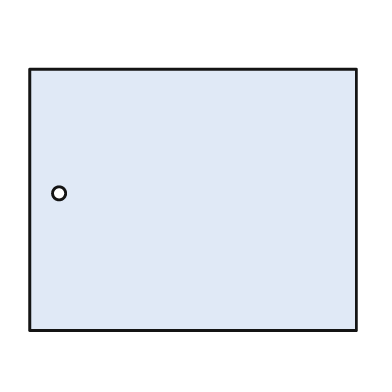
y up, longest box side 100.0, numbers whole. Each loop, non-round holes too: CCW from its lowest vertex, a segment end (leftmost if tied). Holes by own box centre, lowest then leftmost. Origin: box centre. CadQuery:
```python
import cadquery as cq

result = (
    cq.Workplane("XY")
    .moveTo(-50.0, -40.0)
    .lineTo(50.0, -40.0)
    .lineTo(50.0, 40.0)
    .lineTo(-50.0, 40.0)
    .close()
    .moveTo(-41.0, 2.0)
    .circle(2.0)
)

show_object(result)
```